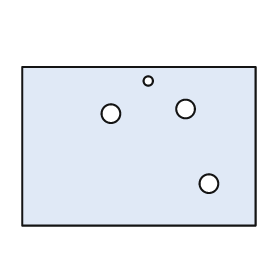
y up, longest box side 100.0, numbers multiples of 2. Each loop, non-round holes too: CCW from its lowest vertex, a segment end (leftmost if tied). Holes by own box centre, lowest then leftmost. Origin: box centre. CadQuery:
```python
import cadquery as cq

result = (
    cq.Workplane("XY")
    .moveTo(-50.0, -34.0)
    .lineTo(50.0, -34.0)
    .lineTo(50.0, 34.0)
    .lineTo(-50.0, 34.0)
    .close()
    .moveTo(30.0, -16.0)
    .circle(4.0)
    .moveTo(-12.0, 14.0)
    .circle(4.0)
    .moveTo(20.0, 16.0)
    .circle(4.0)
    .moveTo(4.0, 28.0)
    .circle(2.0)
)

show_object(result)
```